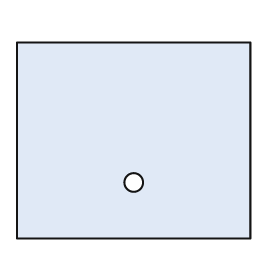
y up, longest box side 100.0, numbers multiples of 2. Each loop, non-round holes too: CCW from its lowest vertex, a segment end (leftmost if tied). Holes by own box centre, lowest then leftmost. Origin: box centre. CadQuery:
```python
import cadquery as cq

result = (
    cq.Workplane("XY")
    .moveTo(-50.0, -42.0)
    .lineTo(50.0, -42.0)
    .lineTo(50.0, 42.0)
    .lineTo(-50.0, 42.0)
    .close()
    .moveTo(0.0, -18.0)
    .circle(4.0)
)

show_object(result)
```